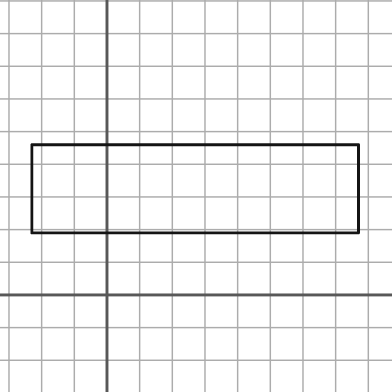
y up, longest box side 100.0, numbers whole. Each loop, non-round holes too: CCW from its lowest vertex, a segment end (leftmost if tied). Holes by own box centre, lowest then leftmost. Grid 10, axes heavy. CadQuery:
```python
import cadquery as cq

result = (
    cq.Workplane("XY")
    .moveTo(-23.0, 19.0)
    .lineTo(77.0, 19.0)
    .lineTo(77.0, 46.0)
    .lineTo(-23.0, 46.0)
    .close()
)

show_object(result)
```